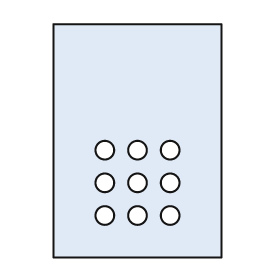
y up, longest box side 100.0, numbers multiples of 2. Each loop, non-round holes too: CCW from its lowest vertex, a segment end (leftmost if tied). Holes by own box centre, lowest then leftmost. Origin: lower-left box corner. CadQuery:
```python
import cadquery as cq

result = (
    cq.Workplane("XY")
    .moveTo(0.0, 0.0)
    .lineTo(72.0, 0.0)
    .lineTo(72.0, 100.0)
    .lineTo(0.0, 100.0)
    .close()
    .moveTo(22.0, 18.0)
    .circle(4.0)
    .moveTo(36.0, 18.0)
    .circle(4.0)
    .moveTo(50.0, 18.0)
    .circle(4.0)
    .moveTo(22.0, 32.0)
    .circle(4.0)
    .moveTo(36.0, 32.0)
    .circle(4.0)
    .moveTo(50.0, 32.0)
    .circle(4.0)
    .moveTo(22.0, 46.0)
    .circle(4.0)
    .moveTo(36.0, 46.0)
    .circle(4.0)
    .moveTo(50.0, 46.0)
    .circle(4.0)
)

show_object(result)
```